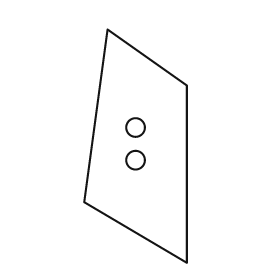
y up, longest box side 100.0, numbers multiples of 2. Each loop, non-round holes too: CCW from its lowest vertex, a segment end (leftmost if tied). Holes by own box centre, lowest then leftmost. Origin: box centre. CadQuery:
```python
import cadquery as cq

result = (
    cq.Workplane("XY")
    .moveTo(22.0, -50.0)
    .lineTo(22.0, 26.0)
    .lineTo(-12.0, 50.0)
    .lineTo(-22.0, -24.0)
    .close()
    .moveTo(0.0, -6.0)
    .circle(4.0)
    .moveTo(0.0, 8.0)
    .circle(4.0)
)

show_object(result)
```